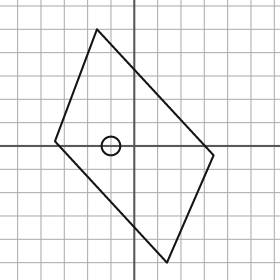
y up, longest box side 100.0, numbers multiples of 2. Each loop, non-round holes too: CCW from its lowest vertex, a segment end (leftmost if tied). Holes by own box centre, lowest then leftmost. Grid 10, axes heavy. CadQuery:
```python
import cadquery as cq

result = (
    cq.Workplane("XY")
    .moveTo(14.0, -50.0)
    .lineTo(34.0, -4.0)
    .lineTo(-16.0, 50.0)
    .lineTo(-34.0, 2.0)
    .close()
    .moveTo(-10.0, 0.0)
    .circle(4.0)
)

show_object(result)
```